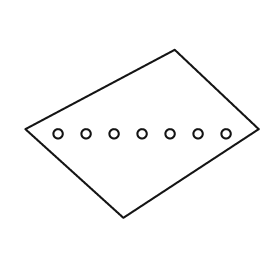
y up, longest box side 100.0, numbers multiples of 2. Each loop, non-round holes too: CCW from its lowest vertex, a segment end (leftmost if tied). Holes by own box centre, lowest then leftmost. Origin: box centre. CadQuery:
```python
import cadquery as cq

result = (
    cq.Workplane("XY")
    .moveTo(-8.0, -36.0)
    .lineTo(50.0, 2.0)
    .lineTo(14.0, 36.0)
    .lineTo(-50.0, 2.0)
    .close()
    .moveTo(-36.0, 0.0)
    .circle(2.0)
    .moveTo(-24.0, 0.0)
    .circle(2.0)
    .moveTo(-12.0, 0.0)
    .circle(2.0)
    .moveTo(0.0, 0.0)
    .circle(2.0)
    .moveTo(12.0, 0.0)
    .circle(2.0)
    .moveTo(24.0, 0.0)
    .circle(2.0)
    .moveTo(36.0, 0.0)
    .circle(2.0)
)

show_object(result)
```